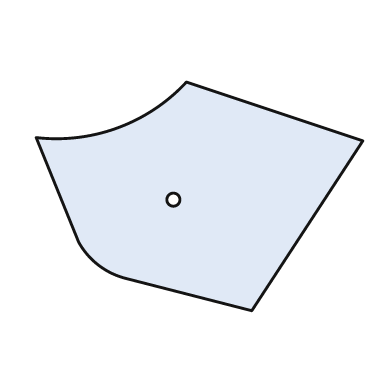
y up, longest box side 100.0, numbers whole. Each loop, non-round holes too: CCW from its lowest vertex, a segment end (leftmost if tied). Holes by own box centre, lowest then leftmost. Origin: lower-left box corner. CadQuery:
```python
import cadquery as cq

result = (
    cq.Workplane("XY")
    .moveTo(66.0, 0.0)
    .lineTo(100.0, 52.0)
    .lineTo(46.0, 70.0)
    .threePointArc((25.0, 56.0), (0.0, 53.0))
    .lineTo(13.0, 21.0)
    .threePointArc((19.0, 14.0), (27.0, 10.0))
    .close()
    .moveTo(42.0, 34.0)
    .circle(2.0)
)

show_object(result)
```